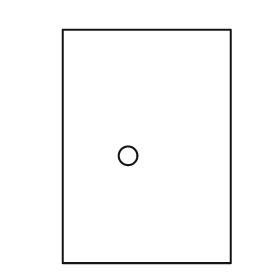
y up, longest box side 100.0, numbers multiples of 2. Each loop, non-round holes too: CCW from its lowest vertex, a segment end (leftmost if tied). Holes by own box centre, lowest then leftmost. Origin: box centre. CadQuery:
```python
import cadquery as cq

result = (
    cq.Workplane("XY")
    .moveTo(-36.0, -50.0)
    .lineTo(36.0, -50.0)
    .lineTo(36.0, 50.0)
    .lineTo(-36.0, 50.0)
    .close()
    .moveTo(-8.0, -4.0)
    .circle(4.0)
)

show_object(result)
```